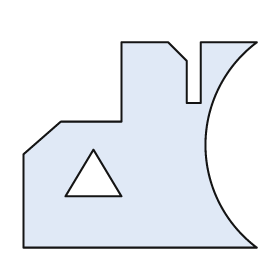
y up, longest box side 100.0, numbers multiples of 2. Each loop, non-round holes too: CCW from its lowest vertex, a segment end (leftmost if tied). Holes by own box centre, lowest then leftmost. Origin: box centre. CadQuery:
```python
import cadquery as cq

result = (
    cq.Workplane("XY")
    .moveTo(-50.0, -44.0)
    .lineTo(50.0, -44.0)
    .threePointArc((28.0, 0.0), (50.0, 44.0))
    .lineTo(26.0, 44.0)
    .lineTo(26.0, 18.0)
    .lineTo(20.0, 18.0)
    .lineTo(20.0, 36.0)
    .lineTo(12.0, 44.0)
    .lineTo(-8.0, 44.0)
    .lineTo(-8.0, 10.0)
    .lineTo(-34.0, 10.0)
    .lineTo(-50.0, -4.0)
    .close()
    .moveTo(-32.0, -22.0)
    .lineTo(-8.0, -22.0)
    .lineTo(-20.0, -2.0)
    .close()
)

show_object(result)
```